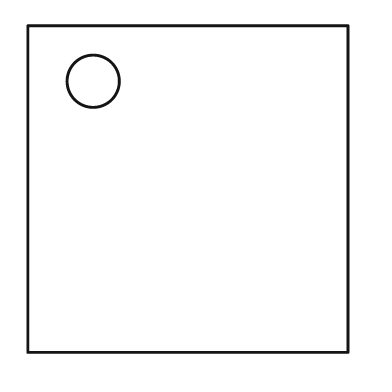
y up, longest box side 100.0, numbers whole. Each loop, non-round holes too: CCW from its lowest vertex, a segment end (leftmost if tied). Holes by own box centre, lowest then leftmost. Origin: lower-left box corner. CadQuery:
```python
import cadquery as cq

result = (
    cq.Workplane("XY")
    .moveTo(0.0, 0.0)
    .lineTo(98.0, 0.0)
    .lineTo(98.0, 100.0)
    .lineTo(0.0, 100.0)
    .close()
    .moveTo(20.0, 83.0)
    .circle(8.0)
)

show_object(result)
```